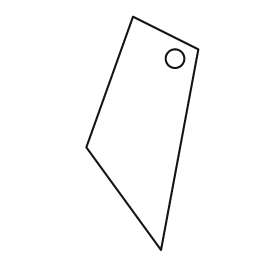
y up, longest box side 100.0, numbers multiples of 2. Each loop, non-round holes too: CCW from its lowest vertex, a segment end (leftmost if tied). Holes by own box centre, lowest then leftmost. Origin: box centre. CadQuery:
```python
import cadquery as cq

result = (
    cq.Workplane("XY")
    .moveTo(8.0, -50.0)
    .lineTo(24.0, 36.0)
    .lineTo(-4.0, 50.0)
    .lineTo(-24.0, -6.0)
    .close()
    .moveTo(14.0, 32.0)
    .circle(4.0)
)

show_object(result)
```